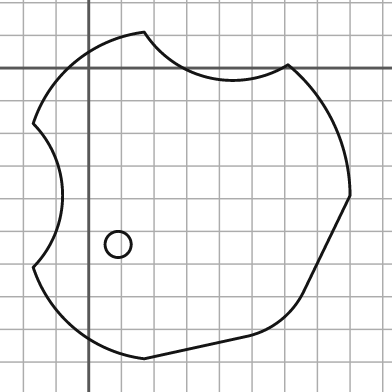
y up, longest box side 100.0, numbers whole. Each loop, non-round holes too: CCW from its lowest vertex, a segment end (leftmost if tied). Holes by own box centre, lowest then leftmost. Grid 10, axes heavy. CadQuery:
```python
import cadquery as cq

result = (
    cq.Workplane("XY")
    .moveTo(17.0, -89.0)
    .lineTo(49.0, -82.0)
    .threePointArc((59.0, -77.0), (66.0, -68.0))
    .lineTo(80.0, -39.0)
    .threePointArc((75.0, -17.0), (61.0, 1.0))
    .threePointArc((37.0, -3.0), (17.0, 11.0))
    .threePointArc((-4.0, 2.0), (-17.0, -17.0))
    .threePointArc((-8.0, -39.0), (-17.0, -61.0))
    .threePointArc((-4.0, -80.0), (17.0, -89.0))
    .close()
    .moveTo(9.0, -54.0)
    .circle(4.0)
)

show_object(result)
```